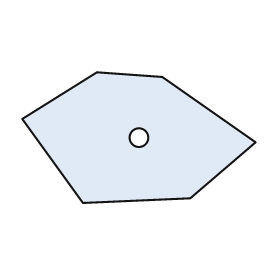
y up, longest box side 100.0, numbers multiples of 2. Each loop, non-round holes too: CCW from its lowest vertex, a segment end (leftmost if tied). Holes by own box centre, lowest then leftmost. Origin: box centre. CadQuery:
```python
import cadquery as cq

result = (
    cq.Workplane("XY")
    .moveTo(-24.0, -28.0)
    .lineTo(22.0, -26.0)
    .lineTo(50.0, -2.0)
    .lineTo(10.0, 26.0)
    .lineTo(-18.0, 28.0)
    .lineTo(-50.0, 8.0)
    .close()
    .moveTo(0.0, 0.0)
    .circle(4.0)
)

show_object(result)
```